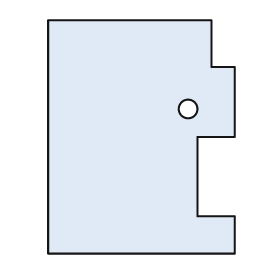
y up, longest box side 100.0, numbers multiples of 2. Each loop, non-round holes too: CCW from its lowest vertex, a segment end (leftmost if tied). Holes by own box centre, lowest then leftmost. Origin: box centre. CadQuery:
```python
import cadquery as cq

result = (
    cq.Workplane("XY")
    .moveTo(-40.0, -50.0)
    .lineTo(40.0, -50.0)
    .lineTo(40.0, -34.0)
    .lineTo(24.0, -34.0)
    .lineTo(24.0, 0.0)
    .lineTo(40.0, 0.0)
    .lineTo(40.0, 30.0)
    .lineTo(30.0, 30.0)
    .lineTo(30.0, 50.0)
    .lineTo(-40.0, 50.0)
    .close()
    .moveTo(20.0, 12.0)
    .circle(4.0)
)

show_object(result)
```